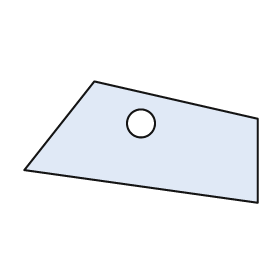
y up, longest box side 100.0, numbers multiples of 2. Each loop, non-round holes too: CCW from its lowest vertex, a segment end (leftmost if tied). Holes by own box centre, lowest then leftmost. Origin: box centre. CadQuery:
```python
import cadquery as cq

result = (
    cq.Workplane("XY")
    .moveTo(50.0, -26.0)
    .lineTo(50.0, 10.0)
    .lineTo(-20.0, 26.0)
    .lineTo(-50.0, -12.0)
    .close()
    .moveTo(0.0, 8.0)
    .circle(6.0)
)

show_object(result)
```